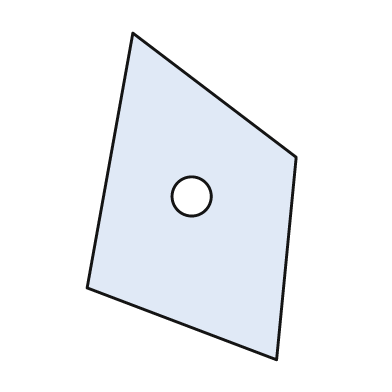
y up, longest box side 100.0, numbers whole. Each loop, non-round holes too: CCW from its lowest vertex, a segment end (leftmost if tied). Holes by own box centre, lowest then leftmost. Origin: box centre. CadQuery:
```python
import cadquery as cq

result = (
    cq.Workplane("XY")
    .moveTo(26.0, -50.0)
    .lineTo(32.0, 12.0)
    .lineTo(-18.0, 50.0)
    .lineTo(-32.0, -28.0)
    .close()
    .moveTo(0.0, 0.0)
    .circle(6.0)
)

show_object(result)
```